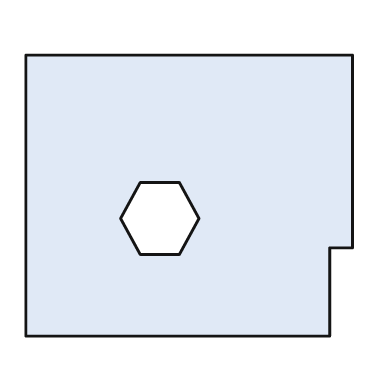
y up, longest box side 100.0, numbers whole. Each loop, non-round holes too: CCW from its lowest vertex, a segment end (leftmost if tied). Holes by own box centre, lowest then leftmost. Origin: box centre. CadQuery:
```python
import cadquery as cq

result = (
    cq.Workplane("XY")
    .moveTo(-50.0, -43.0)
    .lineTo(43.0, -43.0)
    .lineTo(43.0, -16.0)
    .lineTo(50.0, -16.0)
    .lineTo(50.0, 43.0)
    .lineTo(-50.0, 43.0)
    .close()
    .moveTo(-15.0, -18.0)
    .lineTo(-3.0, -18.0)
    .lineTo(3.0, -7.0)
    .lineTo(-3.0, 4.0)
    .lineTo(-15.0, 4.0)
    .lineTo(-21.0, -7.0)
    .close()
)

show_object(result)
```